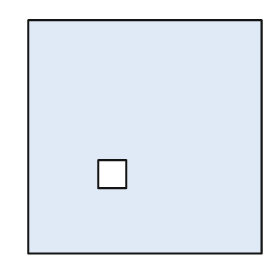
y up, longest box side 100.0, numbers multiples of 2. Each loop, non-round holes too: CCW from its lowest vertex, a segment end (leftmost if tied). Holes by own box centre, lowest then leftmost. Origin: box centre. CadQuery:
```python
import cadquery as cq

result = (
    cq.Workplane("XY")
    .moveTo(-50.0, -50.0)
    .lineTo(50.0, -50.0)
    .lineTo(50.0, 50.0)
    .lineTo(-50.0, 50.0)
    .close()
    .moveTo(-20.0, -22.0)
    .lineTo(-8.0, -22.0)
    .lineTo(-8.0, -10.0)
    .lineTo(-20.0, -10.0)
    .close()
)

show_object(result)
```